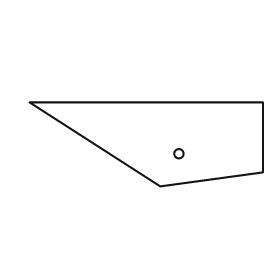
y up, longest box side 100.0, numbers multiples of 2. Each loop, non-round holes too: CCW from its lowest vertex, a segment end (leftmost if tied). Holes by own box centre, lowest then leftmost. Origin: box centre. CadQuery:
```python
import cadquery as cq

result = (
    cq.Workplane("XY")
    .moveTo(6.0, -18.0)
    .lineTo(50.0, -12.0)
    .lineTo(50.0, 18.0)
    .lineTo(-50.0, 18.0)
    .close()
    .moveTo(14.0, -4.0)
    .circle(2.0)
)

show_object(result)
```